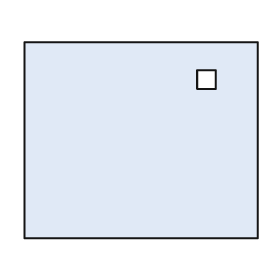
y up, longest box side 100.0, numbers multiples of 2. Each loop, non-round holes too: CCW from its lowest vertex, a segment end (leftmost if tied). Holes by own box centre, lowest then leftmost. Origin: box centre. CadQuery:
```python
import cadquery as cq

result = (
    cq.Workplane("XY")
    .moveTo(-50.0, -42.0)
    .lineTo(50.0, -42.0)
    .lineTo(50.0, 42.0)
    .lineTo(-50.0, 42.0)
    .close()
    .moveTo(24.0, 22.0)
    .lineTo(32.0, 22.0)
    .lineTo(32.0, 30.0)
    .lineTo(24.0, 30.0)
    .close()
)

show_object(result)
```